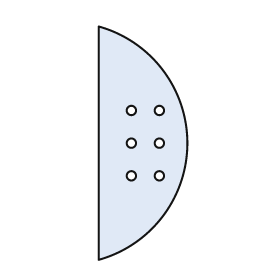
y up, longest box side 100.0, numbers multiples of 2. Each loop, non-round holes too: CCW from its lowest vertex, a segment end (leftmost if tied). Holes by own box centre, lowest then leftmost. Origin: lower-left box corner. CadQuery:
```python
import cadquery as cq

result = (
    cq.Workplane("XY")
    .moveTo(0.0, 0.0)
    .threePointArc((38.0, 50.0), (0.0, 100.0))
    .close()
    .moveTo(14.0, 36.0)
    .circle(2.0)
    .moveTo(26.0, 36.0)
    .circle(2.0)
    .moveTo(14.0, 50.0)
    .circle(2.0)
    .moveTo(26.0, 50.0)
    .circle(2.0)
    .moveTo(14.0, 64.0)
    .circle(2.0)
    .moveTo(26.0, 64.0)
    .circle(2.0)
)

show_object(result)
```